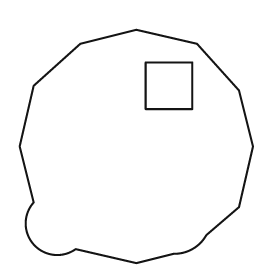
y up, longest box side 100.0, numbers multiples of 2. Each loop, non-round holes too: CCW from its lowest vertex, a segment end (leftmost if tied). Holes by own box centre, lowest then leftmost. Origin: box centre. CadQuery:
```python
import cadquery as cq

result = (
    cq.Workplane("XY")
    .moveTo(0.0, -50.0)
    .lineTo(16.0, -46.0)
    .threePointArc((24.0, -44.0), (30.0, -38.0))
    .lineTo(44.0, -26.0)
    .lineTo(50.0, 0.0)
    .lineTo(44.0, 24.0)
    .lineTo(26.0, 44.0)
    .lineTo(0.0, 50.0)
    .lineTo(-24.0, 44.0)
    .lineTo(-44.0, 26.0)
    .lineTo(-50.0, 0.0)
    .lineTo(-44.0, -24.0)
    .threePointArc((-44.0, -42.0), (-26.0, -44.0))
    .close()
    .moveTo(4.0, 16.0)
    .lineTo(24.0, 16.0)
    .lineTo(24.0, 36.0)
    .lineTo(4.0, 36.0)
    .close()
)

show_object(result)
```